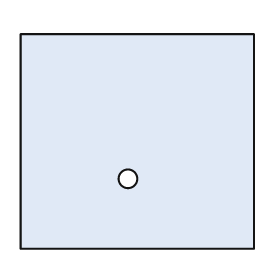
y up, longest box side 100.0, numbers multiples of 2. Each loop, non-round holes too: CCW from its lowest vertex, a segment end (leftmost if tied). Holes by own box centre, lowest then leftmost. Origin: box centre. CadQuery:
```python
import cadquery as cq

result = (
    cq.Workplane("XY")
    .moveTo(-50.0, -46.0)
    .lineTo(50.0, -46.0)
    .lineTo(50.0, 46.0)
    .lineTo(-50.0, 46.0)
    .close()
    .moveTo(-4.0, -16.0)
    .circle(4.0)
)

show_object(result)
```